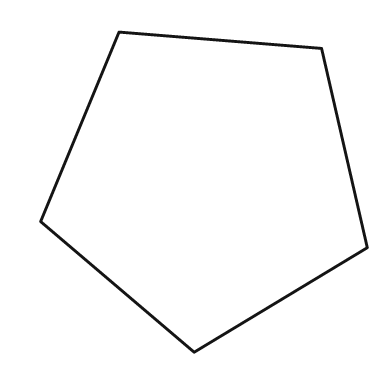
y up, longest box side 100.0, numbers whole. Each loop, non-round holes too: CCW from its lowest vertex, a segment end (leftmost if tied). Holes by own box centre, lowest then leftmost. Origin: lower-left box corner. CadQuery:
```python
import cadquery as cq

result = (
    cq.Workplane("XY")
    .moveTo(47.0, 0.0)
    .lineTo(100.0, 32.0)
    .lineTo(86.0, 93.0)
    .lineTo(24.0, 98.0)
    .lineTo(0.0, 40.0)
    .close()
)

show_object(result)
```